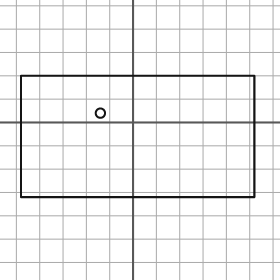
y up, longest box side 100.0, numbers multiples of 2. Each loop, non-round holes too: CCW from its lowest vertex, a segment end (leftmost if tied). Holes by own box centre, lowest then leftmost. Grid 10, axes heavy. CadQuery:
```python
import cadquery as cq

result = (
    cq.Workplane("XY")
    .moveTo(-48.0, -32.0)
    .lineTo(52.0, -32.0)
    .lineTo(52.0, 20.0)
    .lineTo(-48.0, 20.0)
    .close()
    .moveTo(-14.0, 4.0)
    .circle(2.0)
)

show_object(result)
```